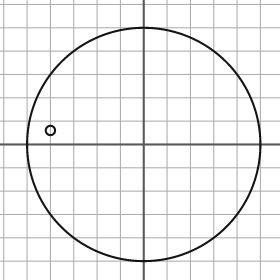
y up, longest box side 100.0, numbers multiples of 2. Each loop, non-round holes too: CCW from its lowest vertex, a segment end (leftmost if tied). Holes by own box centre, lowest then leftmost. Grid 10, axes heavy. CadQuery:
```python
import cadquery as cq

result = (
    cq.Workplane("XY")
    .moveTo(0.0, 0.0)
    .circle(50.0)
    .moveTo(-40.0, 6.0)
    .circle(2.0)
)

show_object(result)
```